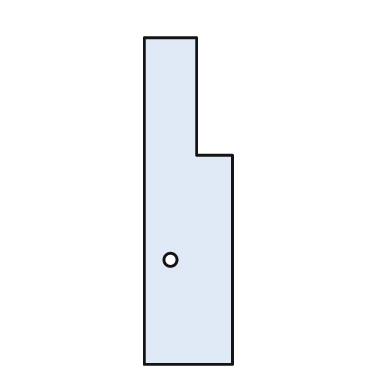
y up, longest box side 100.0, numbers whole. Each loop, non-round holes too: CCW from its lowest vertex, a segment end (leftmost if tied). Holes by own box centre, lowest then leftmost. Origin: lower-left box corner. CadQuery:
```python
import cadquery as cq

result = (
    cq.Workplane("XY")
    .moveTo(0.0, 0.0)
    .lineTo(27.0, 0.0)
    .lineTo(27.0, 64.0)
    .lineTo(16.0, 64.0)
    .lineTo(16.0, 100.0)
    .lineTo(0.0, 100.0)
    .close()
    .moveTo(8.0, 32.0)
    .circle(2.0)
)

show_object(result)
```